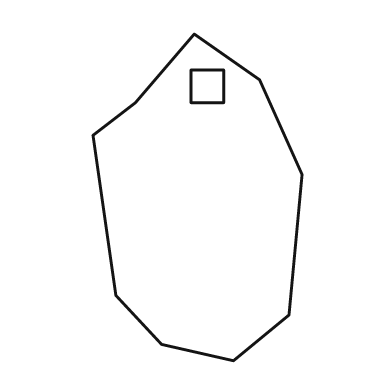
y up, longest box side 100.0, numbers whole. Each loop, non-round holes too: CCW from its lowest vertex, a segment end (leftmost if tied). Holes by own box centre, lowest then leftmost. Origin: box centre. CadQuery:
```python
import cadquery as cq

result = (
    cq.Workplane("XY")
    .moveTo(11.0, -50.0)
    .lineTo(28.0, -36.0)
    .lineTo(32.0, 7.0)
    .lineTo(19.0, 36.0)
    .lineTo(-1.0, 50.0)
    .lineTo(-19.0, 29.0)
    .lineTo(-32.0, 19.0)
    .lineTo(-25.0, -30.0)
    .lineTo(-11.0, -45.0)
    .close()
    .moveTo(-2.0, 29.0)
    .lineTo(8.0, 29.0)
    .lineTo(8.0, 39.0)
    .lineTo(-2.0, 39.0)
    .close()
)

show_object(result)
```